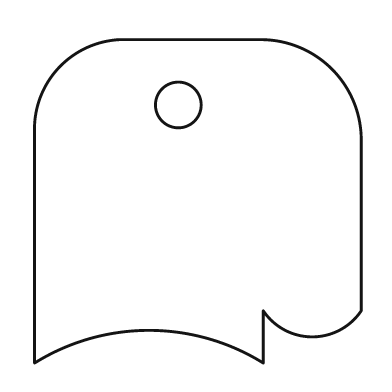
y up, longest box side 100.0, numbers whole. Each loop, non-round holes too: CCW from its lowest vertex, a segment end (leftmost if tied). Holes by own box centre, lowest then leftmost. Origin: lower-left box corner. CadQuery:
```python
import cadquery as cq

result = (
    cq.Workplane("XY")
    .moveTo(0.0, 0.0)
    .threePointArc((35.0, 10.0), (70.0, 0.0))
    .lineTo(70.0, 16.0)
    .threePointArc((85.0, 8.0), (100.0, 16.0))
    .lineTo(100.0, 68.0)
    .threePointArc((91.0, 90.0), (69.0, 99.0))
    .lineTo(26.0, 99.0)
    .threePointArc((8.0, 91.0), (0.0, 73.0))
    .close()
    .moveTo(44.0, 79.0)
    .circle(7.0)
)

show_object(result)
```